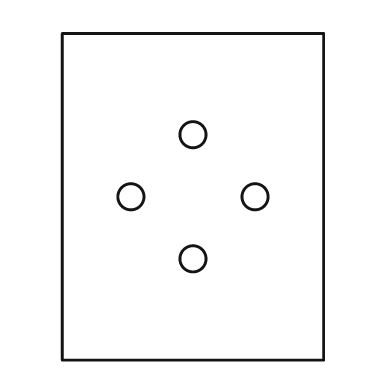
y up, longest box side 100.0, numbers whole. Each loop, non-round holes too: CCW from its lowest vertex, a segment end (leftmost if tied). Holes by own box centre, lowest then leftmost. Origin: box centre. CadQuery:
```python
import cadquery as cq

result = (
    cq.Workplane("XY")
    .moveTo(-40.0, -50.0)
    .lineTo(40.0, -50.0)
    .lineTo(40.0, 50.0)
    .lineTo(-40.0, 50.0)
    .close()
    .moveTo(0.0, -19.0)
    .circle(4.0)
    .moveTo(-19.0, 0.0)
    .circle(4.0)
    .moveTo(19.0, 0.0)
    .circle(4.0)
    .moveTo(0.0, 19.0)
    .circle(4.0)
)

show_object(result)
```